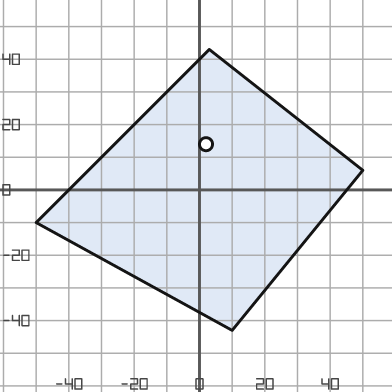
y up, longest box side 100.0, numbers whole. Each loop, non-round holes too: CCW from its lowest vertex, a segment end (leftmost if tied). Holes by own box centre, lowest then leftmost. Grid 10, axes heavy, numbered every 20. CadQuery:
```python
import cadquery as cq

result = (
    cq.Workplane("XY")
    .moveTo(10.0, -43.0)
    .lineTo(50.0, 6.0)
    .lineTo(3.0, 43.0)
    .lineTo(-50.0, -10.0)
    .close()
    .moveTo(2.0, 14.0)
    .circle(2.0)
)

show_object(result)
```